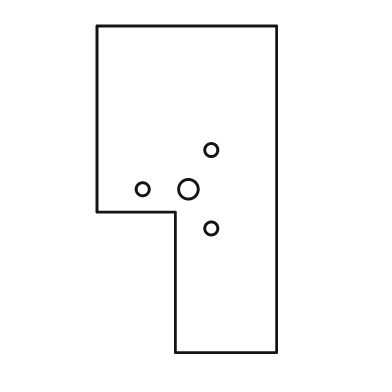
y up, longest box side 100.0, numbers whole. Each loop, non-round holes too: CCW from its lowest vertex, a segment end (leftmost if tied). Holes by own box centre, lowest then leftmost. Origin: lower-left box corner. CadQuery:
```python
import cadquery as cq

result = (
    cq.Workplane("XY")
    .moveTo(24.0, 0.0)
    .lineTo(55.0, 0.0)
    .lineTo(55.0, 100.0)
    .lineTo(0.0, 100.0)
    .lineTo(0.0, 43.0)
    .lineTo(24.0, 43.0)
    .close()
    .moveTo(35.0, 38.0)
    .circle(2.0)
    .moveTo(14.0, 50.0)
    .circle(2.0)
    .moveTo(28.0, 50.0)
    .circle(3.0)
    .moveTo(35.0, 62.0)
    .circle(2.0)
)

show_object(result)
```